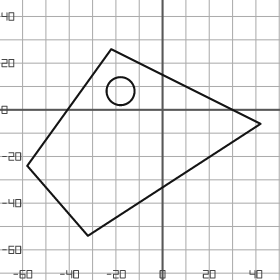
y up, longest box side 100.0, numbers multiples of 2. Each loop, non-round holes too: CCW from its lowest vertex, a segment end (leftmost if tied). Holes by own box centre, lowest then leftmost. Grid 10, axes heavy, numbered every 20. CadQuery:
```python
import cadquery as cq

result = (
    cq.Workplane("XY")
    .moveTo(-32.0, -54.0)
    .lineTo(42.0, -6.0)
    .lineTo(-22.0, 26.0)
    .lineTo(-58.0, -24.0)
    .close()
    .moveTo(-18.0, 8.0)
    .circle(6.0)
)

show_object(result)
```